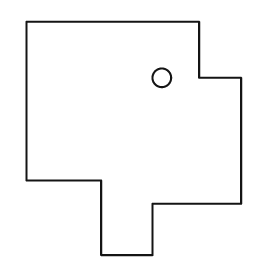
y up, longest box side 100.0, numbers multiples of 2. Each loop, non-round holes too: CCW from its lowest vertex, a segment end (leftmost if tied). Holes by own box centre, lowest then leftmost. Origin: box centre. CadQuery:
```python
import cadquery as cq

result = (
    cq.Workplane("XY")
    .moveTo(-14.0, -50.0)
    .lineTo(8.0, -50.0)
    .lineTo(8.0, -28.0)
    .lineTo(46.0, -28.0)
    .lineTo(46.0, 26.0)
    .lineTo(28.0, 26.0)
    .lineTo(28.0, 50.0)
    .lineTo(-46.0, 50.0)
    .lineTo(-46.0, -18.0)
    .lineTo(-14.0, -18.0)
    .close()
    .moveTo(12.0, 26.0)
    .circle(4.0)
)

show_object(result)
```